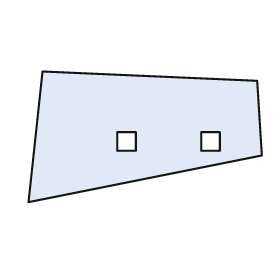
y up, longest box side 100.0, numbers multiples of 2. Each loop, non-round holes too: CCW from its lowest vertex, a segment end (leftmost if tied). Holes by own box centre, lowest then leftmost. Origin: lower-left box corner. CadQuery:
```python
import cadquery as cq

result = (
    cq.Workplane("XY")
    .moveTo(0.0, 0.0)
    .lineTo(100.0, 20.0)
    .lineTo(98.0, 52.0)
    .lineTo(6.0, 56.0)
    .close()
    .moveTo(38.0, 22.0)
    .lineTo(46.0, 22.0)
    .lineTo(46.0, 30.0)
    .lineTo(38.0, 30.0)
    .close()
    .moveTo(74.0, 22.0)
    .lineTo(82.0, 22.0)
    .lineTo(82.0, 30.0)
    .lineTo(74.0, 30.0)
    .close()
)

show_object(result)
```